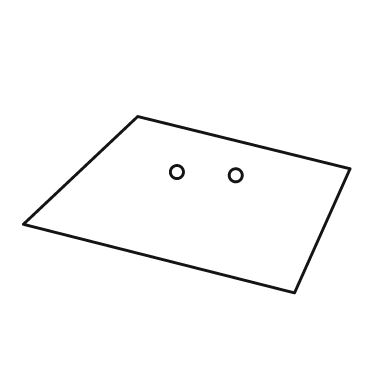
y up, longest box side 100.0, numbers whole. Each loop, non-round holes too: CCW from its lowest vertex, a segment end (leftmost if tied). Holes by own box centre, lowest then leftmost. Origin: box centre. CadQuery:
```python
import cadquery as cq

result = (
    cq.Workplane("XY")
    .moveTo(33.0, -27.0)
    .lineTo(50.0, 11.0)
    .lineTo(-15.0, 27.0)
    .lineTo(-50.0, -6.0)
    .close()
    .moveTo(15.0, 9.0)
    .circle(2.0)
    .moveTo(-3.0, 10.0)
    .circle(2.0)
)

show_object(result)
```